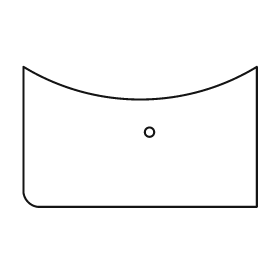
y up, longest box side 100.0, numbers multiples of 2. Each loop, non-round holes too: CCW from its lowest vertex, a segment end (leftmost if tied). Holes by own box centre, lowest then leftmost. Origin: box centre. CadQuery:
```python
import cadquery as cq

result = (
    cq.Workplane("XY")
    .moveTo(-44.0, -30.0)
    .lineTo(50.0, -30.0)
    .lineTo(50.0, 30.0)
    .threePointArc((0.0, 16.0), (-50.0, 30.0))
    .lineTo(-50.0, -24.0)
    .threePointArc((-48.0, -28.0), (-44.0, -30.0))
    .close()
    .moveTo(4.0, 2.0)
    .circle(2.0)
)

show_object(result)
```